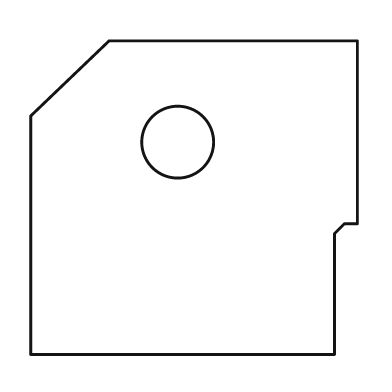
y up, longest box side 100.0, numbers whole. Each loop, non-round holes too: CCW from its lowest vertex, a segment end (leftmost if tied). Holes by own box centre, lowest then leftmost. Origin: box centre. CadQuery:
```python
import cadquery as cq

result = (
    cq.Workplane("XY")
    .moveTo(-50.0, -48.0)
    .lineTo(43.0, -48.0)
    .lineTo(43.0, -11.0)
    .lineTo(46.0, -8.0)
    .lineTo(50.0, -8.0)
    .lineTo(50.0, 48.0)
    .lineTo(-26.0, 48.0)
    .lineTo(-50.0, 25.0)
    .close()
    .moveTo(-5.0, 17.0)
    .circle(11.0)
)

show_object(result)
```